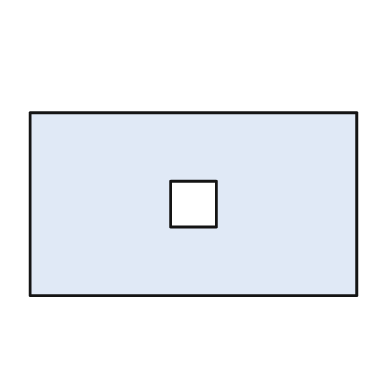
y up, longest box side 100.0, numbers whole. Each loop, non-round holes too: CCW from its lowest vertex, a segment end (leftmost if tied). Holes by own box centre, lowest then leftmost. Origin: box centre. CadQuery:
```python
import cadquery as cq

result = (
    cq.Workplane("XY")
    .moveTo(-50.0, -28.0)
    .lineTo(50.0, -28.0)
    .lineTo(50.0, 28.0)
    .lineTo(-50.0, 28.0)
    .close()
    .moveTo(-7.0, -7.0)
    .lineTo(7.0, -7.0)
    .lineTo(7.0, 7.0)
    .lineTo(-7.0, 7.0)
    .close()
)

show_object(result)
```